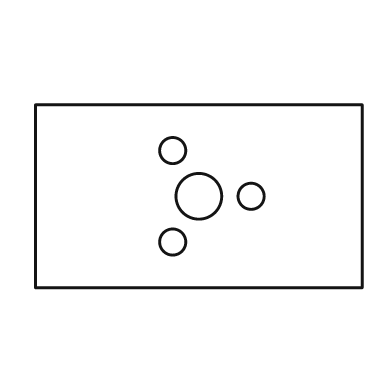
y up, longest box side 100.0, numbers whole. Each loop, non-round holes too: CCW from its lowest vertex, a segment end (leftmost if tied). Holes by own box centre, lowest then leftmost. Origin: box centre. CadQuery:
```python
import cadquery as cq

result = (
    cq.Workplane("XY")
    .moveTo(-50.0, -28.0)
    .lineTo(50.0, -28.0)
    .lineTo(50.0, 28.0)
    .lineTo(-50.0, 28.0)
    .close()
    .moveTo(-8.0, -14.0)
    .circle(4.0)
    .moveTo(0.0, 0.0)
    .circle(7.0)
    .moveTo(16.0, 0.0)
    .circle(4.0)
    .moveTo(-8.0, 14.0)
    .circle(4.0)
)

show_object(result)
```